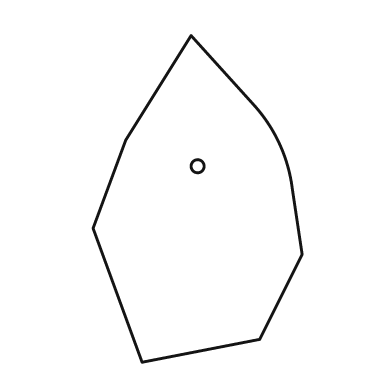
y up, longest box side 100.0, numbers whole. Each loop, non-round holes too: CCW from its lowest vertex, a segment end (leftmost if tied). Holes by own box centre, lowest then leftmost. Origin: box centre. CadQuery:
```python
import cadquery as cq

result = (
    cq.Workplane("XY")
    .moveTo(-17.0, -50.0)
    .lineTo(19.0, -43.0)
    .lineTo(32.0, -17.0)
    .lineTo(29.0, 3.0)
    .threePointArc((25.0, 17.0), (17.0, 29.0))
    .lineTo(-2.0, 50.0)
    .lineTo(-22.0, 18.0)
    .lineTo(-32.0, -9.0)
    .close()
    .moveTo(0.0, 10.0)
    .circle(2.0)
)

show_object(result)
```